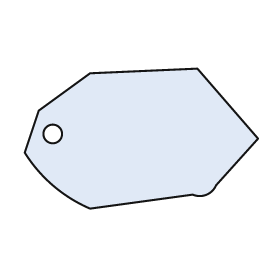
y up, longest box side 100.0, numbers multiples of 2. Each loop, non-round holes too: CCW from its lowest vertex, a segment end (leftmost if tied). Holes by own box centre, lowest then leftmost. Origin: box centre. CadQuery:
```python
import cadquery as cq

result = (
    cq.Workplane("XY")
    .moveTo(-22.0, -30.0)
    .lineTo(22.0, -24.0)
    .threePointArc((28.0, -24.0), (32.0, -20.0))
    .lineTo(50.0, 0.0)
    .lineTo(24.0, 30.0)
    .lineTo(-22.0, 28.0)
    .lineTo(-44.0, 12.0)
    .lineTo(-50.0, -6.0)
    .threePointArc((-38.0, -20.0), (-22.0, -30.0))
    .close()
    .moveTo(-38.0, 2.0)
    .circle(4.0)
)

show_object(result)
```